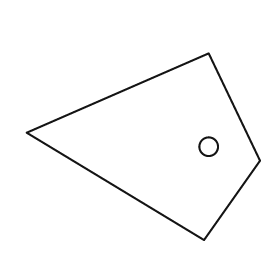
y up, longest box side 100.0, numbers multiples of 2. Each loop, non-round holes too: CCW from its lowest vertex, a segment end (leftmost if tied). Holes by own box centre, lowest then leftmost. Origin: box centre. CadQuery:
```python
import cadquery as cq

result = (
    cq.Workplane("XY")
    .moveTo(26.0, -40.0)
    .lineTo(50.0, -6.0)
    .lineTo(28.0, 40.0)
    .lineTo(-50.0, 6.0)
    .close()
    .moveTo(28.0, 0.0)
    .circle(4.0)
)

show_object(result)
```